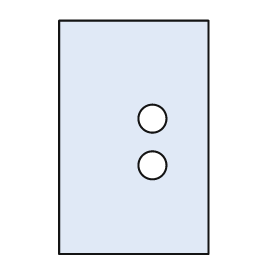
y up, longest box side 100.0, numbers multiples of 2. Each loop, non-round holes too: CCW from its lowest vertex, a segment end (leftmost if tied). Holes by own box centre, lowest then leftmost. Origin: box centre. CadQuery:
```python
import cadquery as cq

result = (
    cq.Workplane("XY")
    .moveTo(-32.0, -50.0)
    .lineTo(32.0, -50.0)
    .lineTo(32.0, 50.0)
    .lineTo(-32.0, 50.0)
    .close()
    .moveTo(8.0, -12.0)
    .circle(6.0)
    .moveTo(8.0, 8.0)
    .circle(6.0)
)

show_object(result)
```